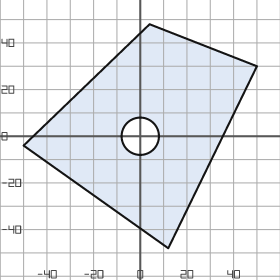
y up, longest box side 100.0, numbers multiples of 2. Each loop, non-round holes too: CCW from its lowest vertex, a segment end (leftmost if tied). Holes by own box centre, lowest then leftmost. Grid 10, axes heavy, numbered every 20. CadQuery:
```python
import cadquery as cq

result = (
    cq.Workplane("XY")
    .moveTo(12.0, -48.0)
    .lineTo(50.0, 30.0)
    .lineTo(4.0, 48.0)
    .lineTo(-50.0, -4.0)
    .close()
    .moveTo(0.0, 0.0)
    .circle(8.0)
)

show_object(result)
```